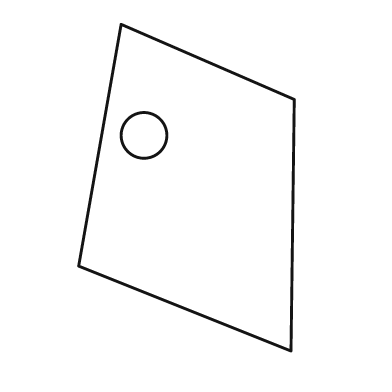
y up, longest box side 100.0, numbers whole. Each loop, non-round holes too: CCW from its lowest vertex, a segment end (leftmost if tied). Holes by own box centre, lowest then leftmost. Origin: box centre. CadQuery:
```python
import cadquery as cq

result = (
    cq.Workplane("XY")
    .moveTo(32.0, -50.0)
    .lineTo(33.0, 27.0)
    .lineTo(-20.0, 50.0)
    .lineTo(-33.0, -24.0)
    .close()
    .moveTo(-13.0, 16.0)
    .circle(7.0)
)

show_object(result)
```